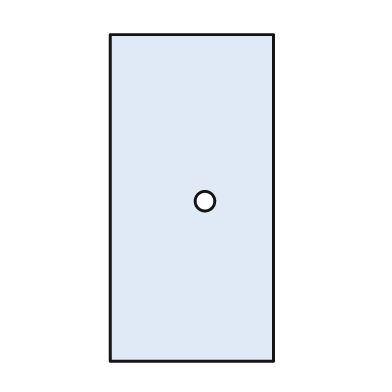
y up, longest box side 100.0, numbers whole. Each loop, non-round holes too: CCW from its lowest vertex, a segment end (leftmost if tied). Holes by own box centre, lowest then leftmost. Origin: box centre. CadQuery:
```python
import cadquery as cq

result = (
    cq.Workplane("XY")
    .moveTo(-25.0, -50.0)
    .lineTo(25.0, -50.0)
    .lineTo(25.0, 50.0)
    .lineTo(-25.0, 50.0)
    .close()
    .moveTo(4.0, -1.0)
    .circle(3.0)
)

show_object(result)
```